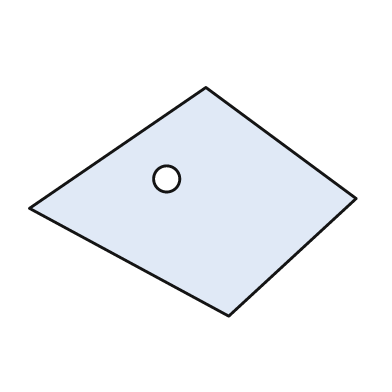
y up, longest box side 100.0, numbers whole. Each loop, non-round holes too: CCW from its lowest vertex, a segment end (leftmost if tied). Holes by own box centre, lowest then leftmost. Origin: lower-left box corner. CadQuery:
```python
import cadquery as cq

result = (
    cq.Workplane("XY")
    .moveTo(61.0, 0.0)
    .lineTo(100.0, 36.0)
    .lineTo(54.0, 70.0)
    .lineTo(0.0, 33.0)
    .close()
    .moveTo(42.0, 42.0)
    .circle(4.0)
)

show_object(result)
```